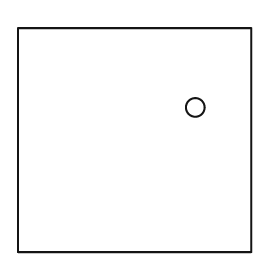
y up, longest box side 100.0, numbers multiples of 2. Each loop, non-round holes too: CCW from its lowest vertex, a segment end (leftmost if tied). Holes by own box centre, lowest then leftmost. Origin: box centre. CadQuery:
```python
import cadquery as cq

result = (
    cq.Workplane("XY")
    .moveTo(-50.0, -48.0)
    .lineTo(50.0, -48.0)
    .lineTo(50.0, 48.0)
    .lineTo(-50.0, 48.0)
    .close()
    .moveTo(26.0, 14.0)
    .circle(4.0)
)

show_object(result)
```